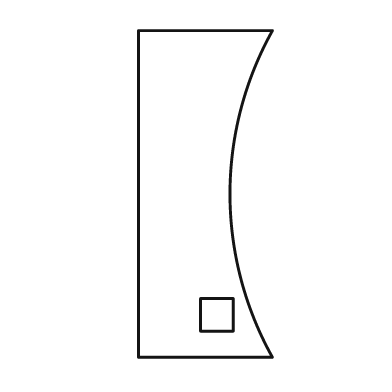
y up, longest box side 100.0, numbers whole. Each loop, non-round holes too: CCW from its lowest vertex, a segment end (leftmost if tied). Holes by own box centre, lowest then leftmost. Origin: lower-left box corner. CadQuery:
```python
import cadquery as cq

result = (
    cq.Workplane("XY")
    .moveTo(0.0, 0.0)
    .lineTo(41.0, 0.0)
    .threePointArc((28.0, 50.0), (41.0, 100.0))
    .lineTo(0.0, 100.0)
    .close()
    .moveTo(19.0, 8.0)
    .lineTo(29.0, 8.0)
    .lineTo(29.0, 18.0)
    .lineTo(19.0, 18.0)
    .close()
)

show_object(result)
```